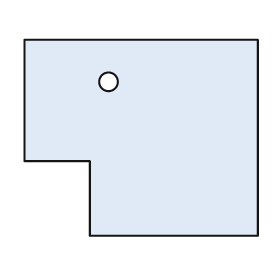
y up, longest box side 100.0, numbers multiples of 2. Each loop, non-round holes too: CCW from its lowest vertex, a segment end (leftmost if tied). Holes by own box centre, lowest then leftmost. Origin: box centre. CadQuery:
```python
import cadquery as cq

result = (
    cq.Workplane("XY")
    .moveTo(-22.0, -42.0)
    .lineTo(50.0, -42.0)
    .lineTo(50.0, 42.0)
    .lineTo(-50.0, 42.0)
    .lineTo(-50.0, -10.0)
    .lineTo(-22.0, -10.0)
    .close()
    .moveTo(-14.0, 24.0)
    .circle(4.0)
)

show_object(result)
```